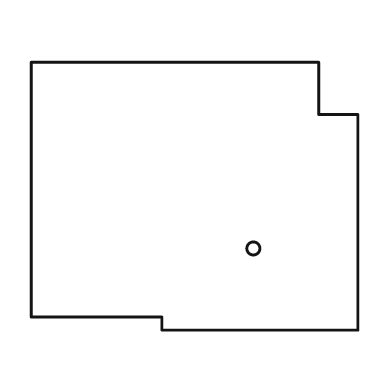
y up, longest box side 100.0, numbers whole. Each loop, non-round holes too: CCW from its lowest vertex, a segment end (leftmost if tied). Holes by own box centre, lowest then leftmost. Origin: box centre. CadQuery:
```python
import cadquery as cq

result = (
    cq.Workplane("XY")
    .moveTo(-10.0, -41.0)
    .lineTo(50.0, -41.0)
    .lineTo(50.0, 25.0)
    .lineTo(38.0, 25.0)
    .lineTo(38.0, 41.0)
    .lineTo(-50.0, 41.0)
    .lineTo(-50.0, -37.0)
    .lineTo(-10.0, -37.0)
    .close()
    .moveTo(18.0, -16.0)
    .circle(2.0)
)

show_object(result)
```